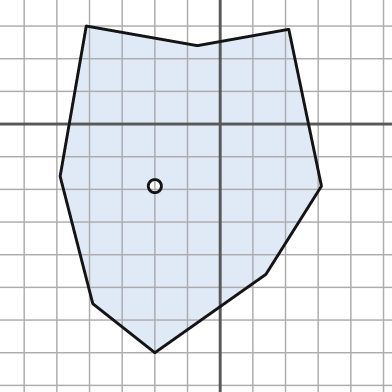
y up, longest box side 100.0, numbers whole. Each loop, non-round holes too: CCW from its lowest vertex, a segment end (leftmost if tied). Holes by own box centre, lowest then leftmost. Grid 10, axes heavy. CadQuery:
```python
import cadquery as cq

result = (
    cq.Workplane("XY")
    .moveTo(-20.0, -70.0)
    .lineTo(14.0, -46.0)
    .lineTo(31.0, -19.0)
    .lineTo(21.0, 29.0)
    .lineTo(-7.0, 24.0)
    .lineTo(-41.0, 30.0)
    .lineTo(-49.0, -16.0)
    .lineTo(-39.0, -55.0)
    .close()
    .moveTo(-20.0, -19.0)
    .circle(2.0)
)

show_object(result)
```